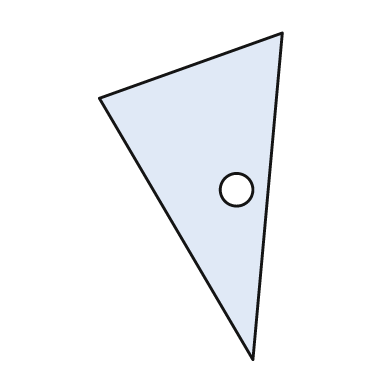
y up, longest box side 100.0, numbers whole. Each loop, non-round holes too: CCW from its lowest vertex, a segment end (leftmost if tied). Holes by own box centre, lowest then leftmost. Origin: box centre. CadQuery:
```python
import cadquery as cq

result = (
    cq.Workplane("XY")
    .moveTo(19.0, -50.0)
    .lineTo(28.0, 50.0)
    .lineTo(-28.0, 30.0)
    .close()
    .moveTo(14.0, 2.0)
    .circle(5.0)
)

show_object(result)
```